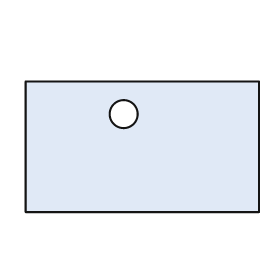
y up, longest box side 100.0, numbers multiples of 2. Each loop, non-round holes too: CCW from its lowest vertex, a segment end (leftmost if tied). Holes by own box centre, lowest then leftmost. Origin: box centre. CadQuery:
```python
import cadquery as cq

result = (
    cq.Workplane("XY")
    .moveTo(-50.0, -28.0)
    .lineTo(50.0, -28.0)
    .lineTo(50.0, 28.0)
    .lineTo(-50.0, 28.0)
    .close()
    .moveTo(-8.0, 14.0)
    .circle(6.0)
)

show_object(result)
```